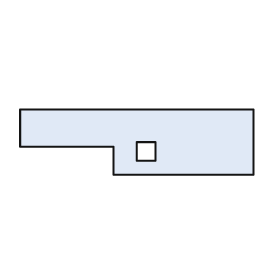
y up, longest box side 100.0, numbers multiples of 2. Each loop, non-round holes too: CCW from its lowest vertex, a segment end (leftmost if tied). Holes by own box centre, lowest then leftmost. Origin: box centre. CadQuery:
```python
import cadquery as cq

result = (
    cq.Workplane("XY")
    .moveTo(-10.0, -14.0)
    .lineTo(50.0, -14.0)
    .lineTo(50.0, 14.0)
    .lineTo(-50.0, 14.0)
    .lineTo(-50.0, -2.0)
    .lineTo(-10.0, -2.0)
    .close()
    .moveTo(0.0, -8.0)
    .lineTo(8.0, -8.0)
    .lineTo(8.0, 0.0)
    .lineTo(0.0, 0.0)
    .close()
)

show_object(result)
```